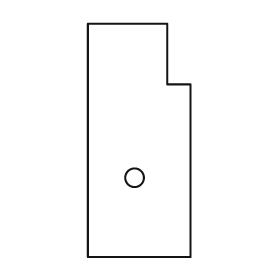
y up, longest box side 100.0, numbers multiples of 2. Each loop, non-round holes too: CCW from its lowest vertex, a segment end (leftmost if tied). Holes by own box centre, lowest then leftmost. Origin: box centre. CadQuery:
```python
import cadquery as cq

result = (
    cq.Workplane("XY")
    .moveTo(-22.0, -50.0)
    .lineTo(22.0, -50.0)
    .lineTo(22.0, 24.0)
    .lineTo(12.0, 24.0)
    .lineTo(12.0, 50.0)
    .lineTo(-22.0, 50.0)
    .close()
    .moveTo(-2.0, -16.0)
    .circle(4.0)
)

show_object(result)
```